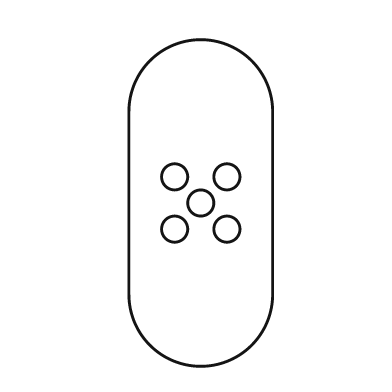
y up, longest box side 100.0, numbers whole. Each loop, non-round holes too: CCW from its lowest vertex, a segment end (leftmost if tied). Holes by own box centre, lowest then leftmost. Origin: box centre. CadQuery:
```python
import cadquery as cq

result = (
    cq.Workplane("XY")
    .moveTo(-22.0, -28.0)
    .threePointArc((0.0, -50.0), (22.0, -28.0))
    .lineTo(22.0, 28.0)
    .threePointArc((0.0, 50.0), (-22.0, 28.0))
    .close()
    .moveTo(-8.0, -8.0)
    .circle(4.0)
    .moveTo(8.0, -8.0)
    .circle(4.0)
    .moveTo(0.0, 0.0)
    .circle(4.0)
    .moveTo(-8.0, 8.0)
    .circle(4.0)
    .moveTo(8.0, 8.0)
    .circle(4.0)
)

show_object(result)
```